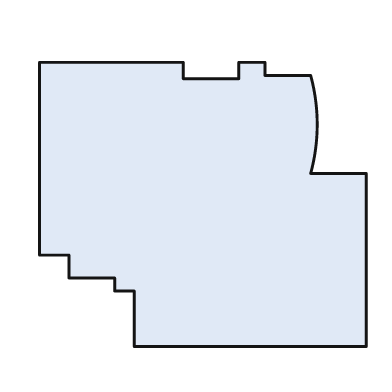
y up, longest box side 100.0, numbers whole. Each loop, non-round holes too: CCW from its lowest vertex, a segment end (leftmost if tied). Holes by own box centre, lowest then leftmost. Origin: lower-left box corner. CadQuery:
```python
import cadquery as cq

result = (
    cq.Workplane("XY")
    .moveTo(29.0, 0.0)
    .lineTo(100.0, 0.0)
    .lineTo(100.0, 53.0)
    .lineTo(83.0, 53.0)
    .threePointArc((85.0, 68.0), (83.0, 83.0))
    .lineTo(69.0, 83.0)
    .lineTo(69.0, 87.0)
    .lineTo(61.0, 87.0)
    .lineTo(61.0, 82.0)
    .lineTo(44.0, 82.0)
    .lineTo(44.0, 87.0)
    .lineTo(0.0, 87.0)
    .lineTo(0.0, 28.0)
    .lineTo(9.0, 28.0)
    .lineTo(9.0, 21.0)
    .lineTo(23.0, 21.0)
    .lineTo(23.0, 17.0)
    .lineTo(29.0, 17.0)
    .close()
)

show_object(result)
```